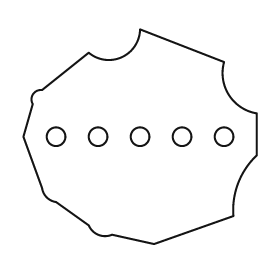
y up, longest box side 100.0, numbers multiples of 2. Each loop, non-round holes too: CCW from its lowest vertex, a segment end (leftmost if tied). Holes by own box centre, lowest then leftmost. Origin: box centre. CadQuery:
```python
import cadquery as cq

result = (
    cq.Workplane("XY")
    .moveTo(6.0, -46.0)
    .lineTo(40.0, -34.0)
    .threePointArc((42.0, -20.0), (50.0, -8.0))
    .lineTo(50.0, 10.0)
    .threePointArc((38.0, 18.0), (36.0, 32.0))
    .lineTo(0.0, 46.0)
    .threePointArc((-8.0, 34.0), (-22.0, 36.0))
    .lineTo(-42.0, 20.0)
    .threePointArc((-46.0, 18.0), (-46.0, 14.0))
    .lineTo(-50.0, 0.0)
    .lineTo(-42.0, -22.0)
    .threePointArc((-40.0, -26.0), (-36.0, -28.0))
    .lineTo(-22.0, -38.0)
    .threePointArc((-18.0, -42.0), (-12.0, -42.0))
    .close()
    .moveTo(-36.0, 0.0)
    .circle(4.0)
    .moveTo(-18.0, 0.0)
    .circle(4.0)
    .moveTo(0.0, 0.0)
    .circle(4.0)
    .moveTo(18.0, 0.0)
    .circle(4.0)
    .moveTo(36.0, 0.0)
    .circle(4.0)
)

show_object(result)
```